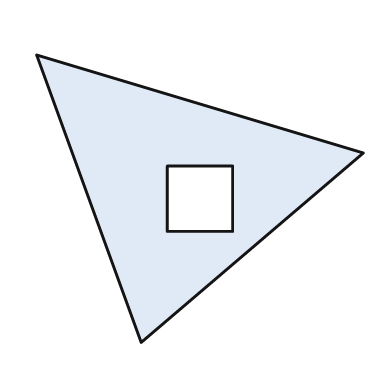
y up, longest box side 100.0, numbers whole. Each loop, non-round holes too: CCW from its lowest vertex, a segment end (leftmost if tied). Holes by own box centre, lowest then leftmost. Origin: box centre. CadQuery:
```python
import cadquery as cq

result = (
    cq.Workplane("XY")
    .moveTo(-18.0, -44.0)
    .lineTo(50.0, 14.0)
    .lineTo(-50.0, 44.0)
    .close()
    .moveTo(-10.0, -10.0)
    .lineTo(10.0, -10.0)
    .lineTo(10.0, 10.0)
    .lineTo(-10.0, 10.0)
    .close()
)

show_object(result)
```